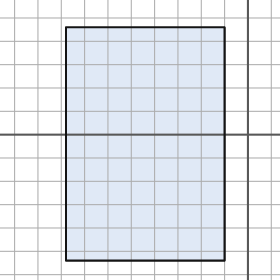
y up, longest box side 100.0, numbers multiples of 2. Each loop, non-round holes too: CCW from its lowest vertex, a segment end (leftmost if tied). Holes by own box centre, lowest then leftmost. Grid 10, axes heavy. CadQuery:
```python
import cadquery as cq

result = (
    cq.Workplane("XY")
    .moveTo(-78.0, -54.0)
    .lineTo(-10.0, -54.0)
    .lineTo(-10.0, 46.0)
    .lineTo(-78.0, 46.0)
    .close()
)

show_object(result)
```